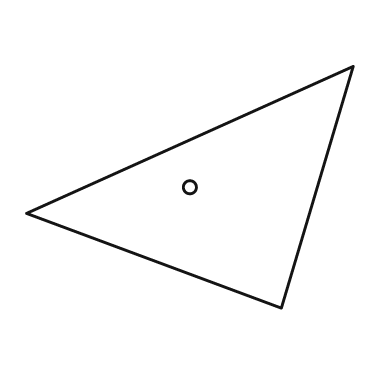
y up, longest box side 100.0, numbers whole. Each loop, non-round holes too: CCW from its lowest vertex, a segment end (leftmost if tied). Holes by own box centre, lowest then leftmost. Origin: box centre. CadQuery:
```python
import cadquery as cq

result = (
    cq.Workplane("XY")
    .moveTo(28.0, -37.0)
    .lineTo(50.0, 37.0)
    .lineTo(-50.0, -8.0)
    .close()
    .moveTo(0.0, 0.0)
    .circle(2.0)
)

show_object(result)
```